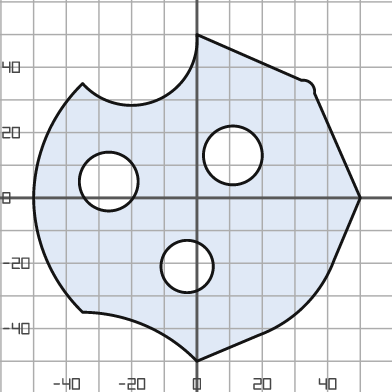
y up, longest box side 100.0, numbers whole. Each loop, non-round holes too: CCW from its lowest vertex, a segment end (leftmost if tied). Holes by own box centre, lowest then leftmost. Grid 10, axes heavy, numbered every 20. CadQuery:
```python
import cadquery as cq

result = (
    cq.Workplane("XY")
    .moveTo(0.0, -50.0)
    .lineTo(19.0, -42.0)
    .threePointArc((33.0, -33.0), (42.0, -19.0))
    .lineTo(50.0, 0.0)
    .lineTo(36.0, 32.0)
    .threePointArc((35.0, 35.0), (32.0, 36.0))
    .lineTo(0.0, 50.0)
    .threePointArc((-12.0, 30.0), (-35.0, 35.0))
    .threePointArc((-46.0, 19.0), (-50.0, 0.0))
    .threePointArc((-46.0, -19.0), (-35.0, -35.0))
    .threePointArc((-16.0, -39.0), (0.0, -50.0))
    .close()
    .moveTo(-3.0, -21.0)
    .circle(8.0)
    .moveTo(-27.0, 5.0)
    .circle(9.0)
    .moveTo(11.0, 13.0)
    .circle(9.0)
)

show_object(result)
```